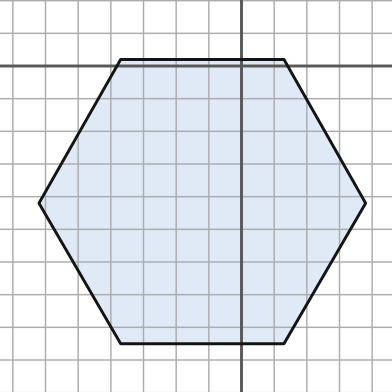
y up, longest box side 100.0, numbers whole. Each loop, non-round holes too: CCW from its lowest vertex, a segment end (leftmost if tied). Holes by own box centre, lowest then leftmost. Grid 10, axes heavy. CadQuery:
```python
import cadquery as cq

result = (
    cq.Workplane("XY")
    .moveTo(-37.0, -85.0)
    .lineTo(13.0, -85.0)
    .lineTo(38.0, -42.0)
    .lineTo(13.0, 2.0)
    .lineTo(-37.0, 2.0)
    .lineTo(-62.0, -42.0)
    .close()
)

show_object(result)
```